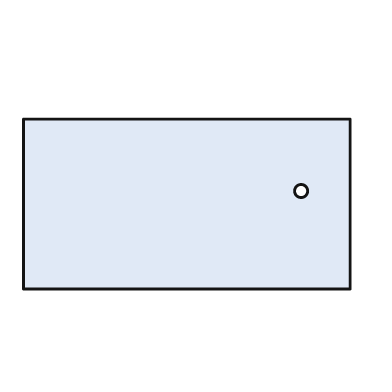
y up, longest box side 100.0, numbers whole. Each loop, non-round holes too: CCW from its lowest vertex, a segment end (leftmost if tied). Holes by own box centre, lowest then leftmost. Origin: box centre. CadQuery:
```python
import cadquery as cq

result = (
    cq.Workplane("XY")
    .moveTo(-50.0, -26.0)
    .lineTo(50.0, -26.0)
    .lineTo(50.0, 26.0)
    .lineTo(-50.0, 26.0)
    .close()
    .moveTo(35.0, 4.0)
    .circle(2.0)
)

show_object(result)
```